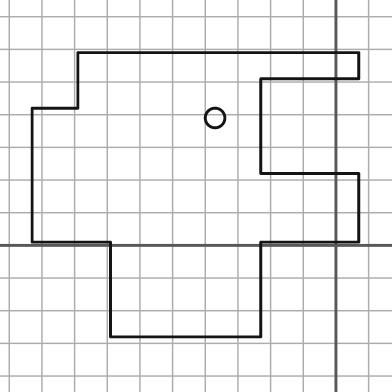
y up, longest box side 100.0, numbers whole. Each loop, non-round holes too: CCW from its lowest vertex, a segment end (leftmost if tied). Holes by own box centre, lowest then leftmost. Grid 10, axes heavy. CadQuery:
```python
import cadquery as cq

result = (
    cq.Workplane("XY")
    .moveTo(-69.0, -28.0)
    .lineTo(-23.0, -28.0)
    .lineTo(-23.0, 1.0)
    .lineTo(7.0, 1.0)
    .lineTo(7.0, 22.0)
    .lineTo(-23.0, 22.0)
    .lineTo(-23.0, 51.0)
    .lineTo(7.0, 51.0)
    .lineTo(7.0, 59.0)
    .lineTo(-79.0, 59.0)
    .lineTo(-79.0, 42.0)
    .lineTo(-93.0, 42.0)
    .lineTo(-93.0, 1.0)
    .lineTo(-69.0, 1.0)
    .close()
    .moveTo(-37.0, 39.0)
    .circle(3.0)
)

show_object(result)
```